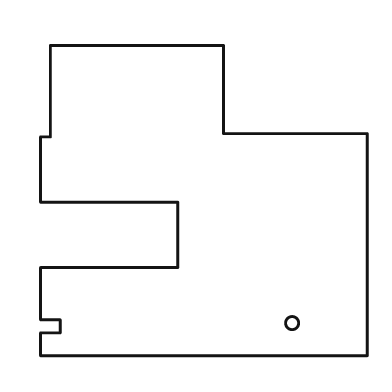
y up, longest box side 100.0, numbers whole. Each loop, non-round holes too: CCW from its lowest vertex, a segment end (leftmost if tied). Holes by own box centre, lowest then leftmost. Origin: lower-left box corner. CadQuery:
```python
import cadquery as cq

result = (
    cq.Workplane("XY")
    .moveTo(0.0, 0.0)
    .lineTo(100.0, 0.0)
    .lineTo(100.0, 68.0)
    .lineTo(56.0, 68.0)
    .lineTo(56.0, 95.0)
    .lineTo(3.0, 95.0)
    .lineTo(3.0, 67.0)
    .lineTo(0.0, 67.0)
    .lineTo(0.0, 47.0)
    .lineTo(42.0, 47.0)
    .lineTo(42.0, 27.0)
    .lineTo(0.0, 27.0)
    .lineTo(0.0, 11.0)
    .lineTo(6.0, 11.0)
    .lineTo(6.0, 7.0)
    .lineTo(0.0, 7.0)
    .close()
    .moveTo(77.0, 10.0)
    .circle(2.0)
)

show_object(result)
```